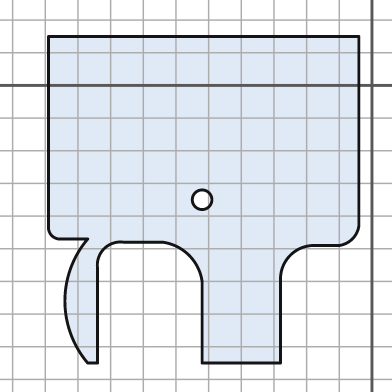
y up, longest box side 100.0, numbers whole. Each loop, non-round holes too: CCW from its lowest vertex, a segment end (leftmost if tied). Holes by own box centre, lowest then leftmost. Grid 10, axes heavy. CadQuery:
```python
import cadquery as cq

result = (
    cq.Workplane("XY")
    .moveTo(-87.0, -85.0)
    .lineTo(-84.0, -85.0)
    .lineTo(-84.0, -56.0)
    .threePointArc((-82.0, -50.0), (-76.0, -48.0))
    .lineTo(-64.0, -48.0)
    .threePointArc((-56.0, -52.0), (-52.0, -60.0))
    .lineTo(-52.0, -85.0)
    .lineTo(-28.0, -85.0)
    .lineTo(-28.0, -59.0)
    .threePointArc((-25.0, -52.0), (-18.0, -49.0))
    .lineTo(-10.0, -49.0)
    .threePointArc((-6.0, -47.0), (-4.0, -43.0))
    .lineTo(-4.0, 15.0)
    .lineTo(-99.0, 15.0)
    .lineTo(-99.0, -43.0)
    .threePointArc((-98.0, -46.0), (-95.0, -47.0))
    .lineTo(-87.0, -47.0)
    .threePointArc((-94.0, -66.0), (-87.0, -85.0))
    .close()
    .moveTo(-52.0, -35.0)
    .circle(3.0)
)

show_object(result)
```